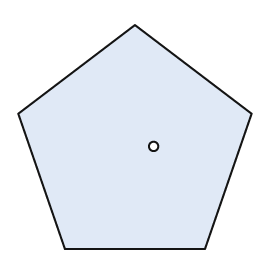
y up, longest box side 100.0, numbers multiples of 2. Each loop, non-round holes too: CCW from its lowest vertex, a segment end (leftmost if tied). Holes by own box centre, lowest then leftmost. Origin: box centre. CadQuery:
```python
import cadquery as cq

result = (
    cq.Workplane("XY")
    .moveTo(-30.0, -48.0)
    .lineTo(30.0, -48.0)
    .lineTo(50.0, 10.0)
    .lineTo(0.0, 48.0)
    .lineTo(-50.0, 10.0)
    .close()
    .moveTo(8.0, -4.0)
    .circle(2.0)
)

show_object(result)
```